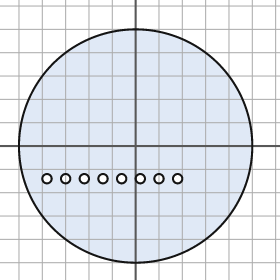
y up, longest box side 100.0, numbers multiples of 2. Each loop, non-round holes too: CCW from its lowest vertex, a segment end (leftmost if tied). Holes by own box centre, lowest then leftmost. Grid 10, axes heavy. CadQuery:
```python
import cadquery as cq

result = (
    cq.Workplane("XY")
    .moveTo(0.0, 0.0)
    .circle(50.0)
    .moveTo(-38.0, -14.0)
    .circle(2.0)
    .moveTo(-30.0, -14.0)
    .circle(2.0)
    .moveTo(-22.0, -14.0)
    .circle(2.0)
    .moveTo(-14.0, -14.0)
    .circle(2.0)
    .moveTo(-6.0, -14.0)
    .circle(2.0)
    .moveTo(2.0, -14.0)
    .circle(2.0)
    .moveTo(10.0, -14.0)
    .circle(2.0)
    .moveTo(18.0, -14.0)
    .circle(2.0)
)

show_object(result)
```